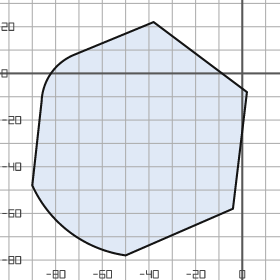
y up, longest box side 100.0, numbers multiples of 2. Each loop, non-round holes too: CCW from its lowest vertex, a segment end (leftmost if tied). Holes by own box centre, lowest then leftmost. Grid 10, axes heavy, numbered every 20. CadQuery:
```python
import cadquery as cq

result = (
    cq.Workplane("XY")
    .moveTo(-50.0, -78.0)
    .lineTo(-4.0, -58.0)
    .lineTo(2.0, -8.0)
    .lineTo(-38.0, 22.0)
    .lineTo(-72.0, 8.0)
    .threePointArc((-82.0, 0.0), (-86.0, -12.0))
    .lineTo(-90.0, -48.0)
    .threePointArc((-74.0, -68.0), (-50.0, -78.0))
    .close()
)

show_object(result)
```